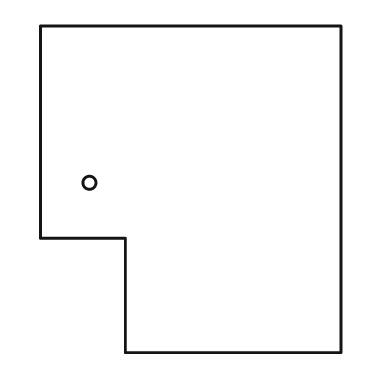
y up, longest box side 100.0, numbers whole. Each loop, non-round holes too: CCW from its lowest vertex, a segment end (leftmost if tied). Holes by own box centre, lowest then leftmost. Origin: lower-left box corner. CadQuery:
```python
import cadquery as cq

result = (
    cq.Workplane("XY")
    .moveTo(26.0, 0.0)
    .lineTo(92.0, 0.0)
    .lineTo(92.0, 100.0)
    .lineTo(0.0, 100.0)
    .lineTo(0.0, 35.0)
    .lineTo(26.0, 35.0)
    .close()
    .moveTo(15.0, 52.0)
    .circle(2.0)
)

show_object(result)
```